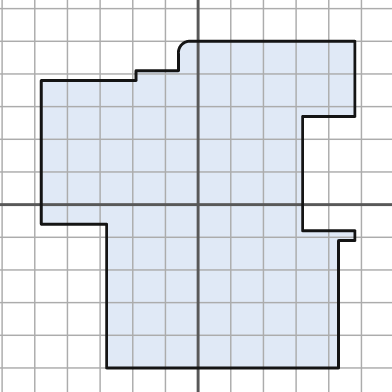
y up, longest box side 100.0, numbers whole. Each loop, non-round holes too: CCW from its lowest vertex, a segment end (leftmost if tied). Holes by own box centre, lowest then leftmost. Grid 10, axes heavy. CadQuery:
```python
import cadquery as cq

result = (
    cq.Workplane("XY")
    .moveTo(-28.0, -50.0)
    .lineTo(43.0, -50.0)
    .lineTo(43.0, -11.0)
    .lineTo(48.0, -11.0)
    .lineTo(48.0, -8.0)
    .lineTo(32.0, -8.0)
    .lineTo(32.0, 27.0)
    .lineTo(48.0, 27.0)
    .lineTo(48.0, 50.0)
    .lineTo(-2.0, 50.0)
    .threePointArc((-5.0, 49.0), (-6.0, 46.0))
    .lineTo(-6.0, 41.0)
    .lineTo(-19.0, 41.0)
    .lineTo(-19.0, 38.0)
    .lineTo(-48.0, 38.0)
    .lineTo(-48.0, -6.0)
    .lineTo(-28.0, -6.0)
    .close()
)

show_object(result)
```